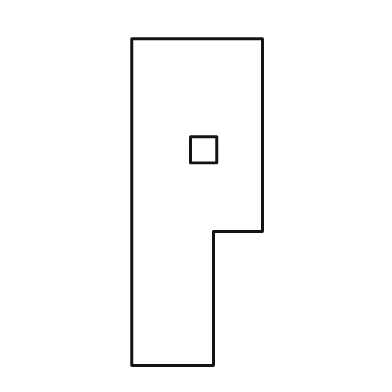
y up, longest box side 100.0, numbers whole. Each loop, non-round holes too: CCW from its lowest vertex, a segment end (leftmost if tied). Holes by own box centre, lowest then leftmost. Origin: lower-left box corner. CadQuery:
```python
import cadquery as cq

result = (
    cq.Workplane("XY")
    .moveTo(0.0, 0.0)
    .lineTo(25.0, 0.0)
    .lineTo(25.0, 41.0)
    .lineTo(40.0, 41.0)
    .lineTo(40.0, 100.0)
    .lineTo(0.0, 100.0)
    .close()
    .moveTo(18.0, 62.0)
    .lineTo(26.0, 62.0)
    .lineTo(26.0, 70.0)
    .lineTo(18.0, 70.0)
    .close()
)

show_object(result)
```